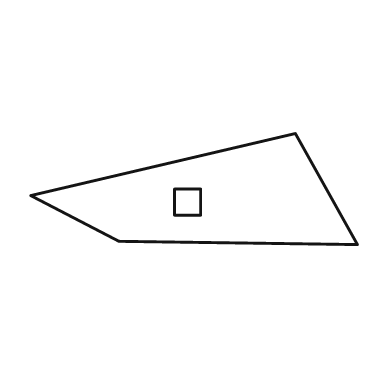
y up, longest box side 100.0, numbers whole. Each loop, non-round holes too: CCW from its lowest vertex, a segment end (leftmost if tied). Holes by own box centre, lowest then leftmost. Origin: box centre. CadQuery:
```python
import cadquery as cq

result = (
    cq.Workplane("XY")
    .moveTo(50.0, -17.0)
    .lineTo(31.0, 17.0)
    .lineTo(-50.0, -2.0)
    .lineTo(-23.0, -16.0)
    .close()
    .moveTo(-6.0, -8.0)
    .lineTo(2.0, -8.0)
    .lineTo(2.0, 0.0)
    .lineTo(-6.0, 0.0)
    .close()
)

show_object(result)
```